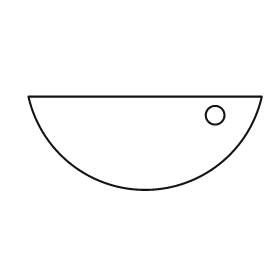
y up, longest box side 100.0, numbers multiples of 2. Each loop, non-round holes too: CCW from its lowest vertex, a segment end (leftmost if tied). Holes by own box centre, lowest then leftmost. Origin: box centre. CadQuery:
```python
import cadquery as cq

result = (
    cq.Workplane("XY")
    .moveTo(-50.0, 20.0)
    .threePointArc((0.0, -20.0), (50.0, 20.0))
    .close()
    .moveTo(30.0, 12.0)
    .circle(4.0)
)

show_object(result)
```